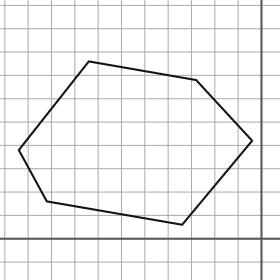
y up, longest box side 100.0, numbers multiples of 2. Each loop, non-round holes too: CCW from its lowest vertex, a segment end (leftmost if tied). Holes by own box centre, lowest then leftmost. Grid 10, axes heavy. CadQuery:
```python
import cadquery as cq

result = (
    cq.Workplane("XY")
    .moveTo(-34.0, 6.0)
    .lineTo(-4.0, 42.0)
    .lineTo(-28.0, 68.0)
    .lineTo(-74.0, 76.0)
    .lineTo(-104.0, 38.0)
    .lineTo(-92.0, 16.0)
    .close()
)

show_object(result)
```